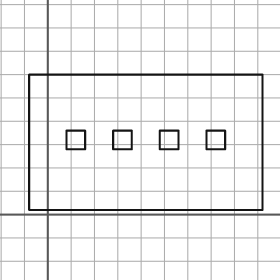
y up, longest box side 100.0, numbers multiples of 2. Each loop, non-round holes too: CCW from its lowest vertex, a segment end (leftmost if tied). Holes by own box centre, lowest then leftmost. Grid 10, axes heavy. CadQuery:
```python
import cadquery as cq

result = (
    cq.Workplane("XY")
    .moveTo(-8.0, 2.0)
    .lineTo(92.0, 2.0)
    .lineTo(92.0, 60.0)
    .lineTo(-8.0, 60.0)
    .close()
    .moveTo(8.0, 28.0)
    .lineTo(16.0, 28.0)
    .lineTo(16.0, 36.0)
    .lineTo(8.0, 36.0)
    .close()
    .moveTo(28.0, 28.0)
    .lineTo(36.0, 28.0)
    .lineTo(36.0, 36.0)
    .lineTo(28.0, 36.0)
    .close()
    .moveTo(48.0, 28.0)
    .lineTo(56.0, 28.0)
    .lineTo(56.0, 36.0)
    .lineTo(48.0, 36.0)
    .close()
    .moveTo(68.0, 28.0)
    .lineTo(76.0, 28.0)
    .lineTo(76.0, 36.0)
    .lineTo(68.0, 36.0)
    .close()
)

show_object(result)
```